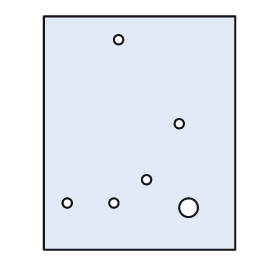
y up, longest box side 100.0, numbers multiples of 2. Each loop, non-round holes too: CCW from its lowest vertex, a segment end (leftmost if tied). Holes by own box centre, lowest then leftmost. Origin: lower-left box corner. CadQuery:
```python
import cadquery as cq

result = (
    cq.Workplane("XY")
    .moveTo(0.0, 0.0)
    .lineTo(82.0, 0.0)
    .lineTo(82.0, 100.0)
    .lineTo(0.0, 100.0)
    .close()
    .moveTo(62.0, 18.0)
    .circle(4.0)
    .moveTo(10.0, 20.0)
    .circle(2.0)
    .moveTo(30.0, 20.0)
    .circle(2.0)
    .moveTo(44.0, 30.0)
    .circle(2.0)
    .moveTo(58.0, 54.0)
    .circle(2.0)
    .moveTo(32.0, 90.0)
    .circle(2.0)
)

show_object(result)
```